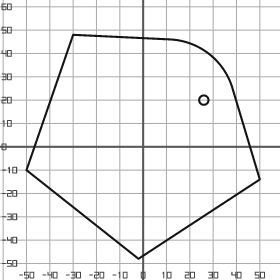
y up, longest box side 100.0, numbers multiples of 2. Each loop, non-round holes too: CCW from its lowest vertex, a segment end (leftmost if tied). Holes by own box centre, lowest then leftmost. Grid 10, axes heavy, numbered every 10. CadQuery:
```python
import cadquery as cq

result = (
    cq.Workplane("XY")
    .moveTo(-2.0, -48.0)
    .lineTo(50.0, -14.0)
    .lineTo(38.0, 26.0)
    .threePointArc((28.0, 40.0), (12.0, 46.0))
    .lineTo(-30.0, 48.0)
    .lineTo(-50.0, -10.0)
    .close()
    .moveTo(26.0, 20.0)
    .circle(2.0)
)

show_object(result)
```